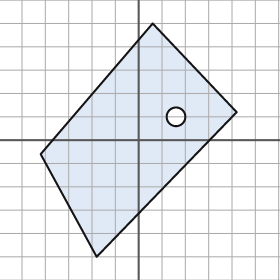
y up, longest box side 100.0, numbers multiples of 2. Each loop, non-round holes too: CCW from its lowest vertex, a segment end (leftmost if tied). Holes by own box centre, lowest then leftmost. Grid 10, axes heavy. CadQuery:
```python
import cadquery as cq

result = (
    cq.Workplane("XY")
    .moveTo(-18.0, -50.0)
    .lineTo(42.0, 12.0)
    .lineTo(6.0, 50.0)
    .lineTo(-42.0, -6.0)
    .close()
    .moveTo(16.0, 10.0)
    .circle(4.0)
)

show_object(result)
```